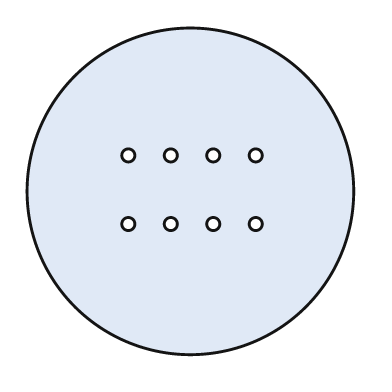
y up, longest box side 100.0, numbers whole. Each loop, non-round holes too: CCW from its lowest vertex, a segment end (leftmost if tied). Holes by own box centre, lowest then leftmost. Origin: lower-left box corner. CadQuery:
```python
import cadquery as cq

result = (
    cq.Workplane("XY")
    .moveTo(50.0, 50.0)
    .circle(50.0)
    .moveTo(31.0, 40.0)
    .circle(2.0)
    .moveTo(44.0, 40.0)
    .circle(2.0)
    .moveTo(57.0, 40.0)
    .circle(2.0)
    .moveTo(70.0, 40.0)
    .circle(2.0)
    .moveTo(31.0, 61.0)
    .circle(2.0)
    .moveTo(44.0, 61.0)
    .circle(2.0)
    .moveTo(57.0, 61.0)
    .circle(2.0)
    .moveTo(70.0, 61.0)
    .circle(2.0)
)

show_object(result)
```